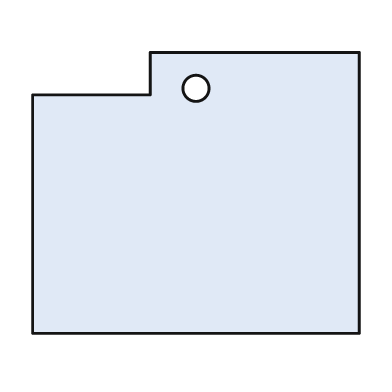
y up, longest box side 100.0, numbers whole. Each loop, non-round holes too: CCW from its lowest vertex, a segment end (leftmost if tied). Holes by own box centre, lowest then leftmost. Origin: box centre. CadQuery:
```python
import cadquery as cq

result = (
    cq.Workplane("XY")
    .moveTo(-50.0, -43.0)
    .lineTo(50.0, -43.0)
    .lineTo(50.0, 43.0)
    .lineTo(-14.0, 43.0)
    .lineTo(-14.0, 30.0)
    .lineTo(-50.0, 30.0)
    .close()
    .moveTo(0.0, 32.0)
    .circle(4.0)
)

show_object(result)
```